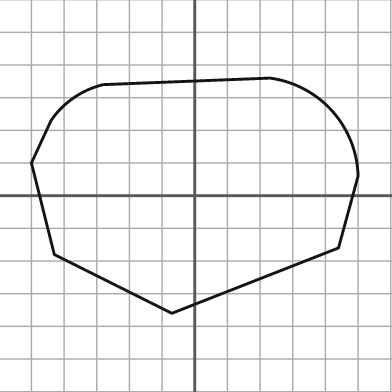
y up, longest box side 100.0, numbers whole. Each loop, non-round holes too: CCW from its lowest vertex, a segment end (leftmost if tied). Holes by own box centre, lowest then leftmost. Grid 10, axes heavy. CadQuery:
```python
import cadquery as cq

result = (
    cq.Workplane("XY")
    .moveTo(-7.0, -36.0)
    .lineTo(44.0, -16.0)
    .lineTo(50.0, 6.0)
    .threePointArc((42.0, 26.0), (23.0, 36.0))
    .lineTo(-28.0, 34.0)
    .threePointArc((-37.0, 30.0), (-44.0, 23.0))
    .lineTo(-50.0, 10.0)
    .lineTo(-43.0, -18.0)
    .close()
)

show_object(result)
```